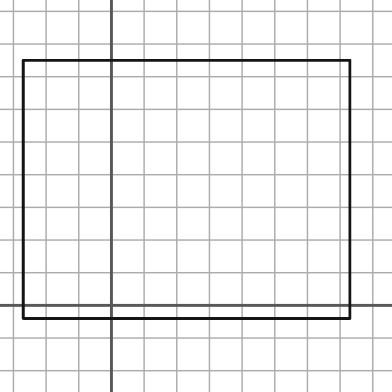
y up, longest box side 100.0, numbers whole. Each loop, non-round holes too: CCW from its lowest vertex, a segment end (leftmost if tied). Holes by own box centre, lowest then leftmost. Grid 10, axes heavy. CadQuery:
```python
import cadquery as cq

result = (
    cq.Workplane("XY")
    .moveTo(-27.0, -4.0)
    .lineTo(73.0, -4.0)
    .lineTo(73.0, 75.0)
    .lineTo(-27.0, 75.0)
    .close()
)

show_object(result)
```